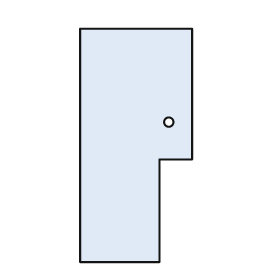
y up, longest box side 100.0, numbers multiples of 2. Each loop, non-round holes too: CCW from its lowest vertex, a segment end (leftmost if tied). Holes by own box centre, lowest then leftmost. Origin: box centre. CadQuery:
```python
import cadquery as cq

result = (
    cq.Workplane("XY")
    .moveTo(-24.0, -50.0)
    .lineTo(10.0, -50.0)
    .lineTo(10.0, -6.0)
    .lineTo(24.0, -6.0)
    .lineTo(24.0, 50.0)
    .lineTo(-24.0, 50.0)
    .close()
    .moveTo(14.0, 10.0)
    .circle(2.0)
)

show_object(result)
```